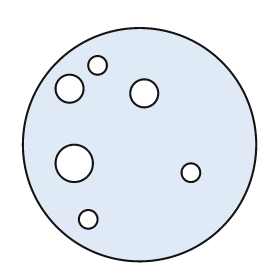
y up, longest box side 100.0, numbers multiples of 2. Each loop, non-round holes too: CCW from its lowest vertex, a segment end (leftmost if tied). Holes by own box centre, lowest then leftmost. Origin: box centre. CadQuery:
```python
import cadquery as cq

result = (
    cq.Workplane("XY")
    .moveTo(0.0, 0.0)
    .circle(50.0)
    .moveTo(-22.0, -32.0)
    .circle(4.0)
    .moveTo(22.0, -12.0)
    .circle(4.0)
    .moveTo(-28.0, -8.0)
    .circle(8.0)
    .moveTo(2.0, 22.0)
    .circle(6.0)
    .moveTo(-30.0, 24.0)
    .circle(6.0)
    .moveTo(-18.0, 34.0)
    .circle(4.0)
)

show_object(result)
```